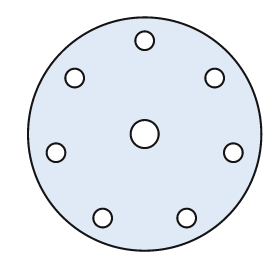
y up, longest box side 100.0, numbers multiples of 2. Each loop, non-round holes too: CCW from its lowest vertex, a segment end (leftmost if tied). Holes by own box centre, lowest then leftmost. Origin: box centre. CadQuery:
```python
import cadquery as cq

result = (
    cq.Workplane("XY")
    .moveTo(0.0, 0.0)
    .circle(50.0)
    .moveTo(-18.0, -36.0)
    .circle(4.0)
    .moveTo(18.0, -36.0)
    .circle(4.0)
    .moveTo(-38.0, -8.0)
    .circle(4.0)
    .moveTo(38.0, -8.0)
    .circle(4.0)
    .moveTo(0.0, 0.0)
    .circle(6.0)
    .moveTo(-30.0, 24.0)
    .circle(4.0)
    .moveTo(30.0, 24.0)
    .circle(4.0)
    .moveTo(0.0, 40.0)
    .circle(4.0)
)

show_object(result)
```